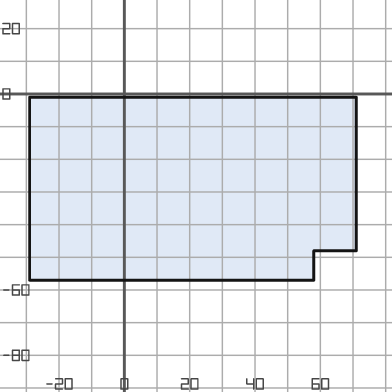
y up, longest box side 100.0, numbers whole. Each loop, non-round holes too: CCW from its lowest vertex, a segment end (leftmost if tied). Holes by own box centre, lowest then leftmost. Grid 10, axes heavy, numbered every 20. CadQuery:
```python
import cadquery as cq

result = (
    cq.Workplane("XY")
    .moveTo(-29.0, -57.0)
    .lineTo(58.0, -57.0)
    .lineTo(58.0, -48.0)
    .lineTo(71.0, -48.0)
    .lineTo(71.0, -1.0)
    .lineTo(-29.0, -1.0)
    .close()
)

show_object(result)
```